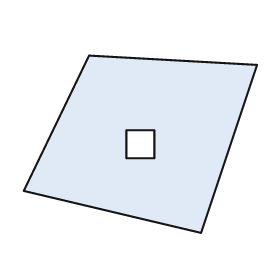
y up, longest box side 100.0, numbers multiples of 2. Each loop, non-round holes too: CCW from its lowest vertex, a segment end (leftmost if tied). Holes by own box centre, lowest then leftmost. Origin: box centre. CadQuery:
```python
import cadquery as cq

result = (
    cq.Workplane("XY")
    .moveTo(26.0, -38.0)
    .lineTo(50.0, 34.0)
    .lineTo(-22.0, 38.0)
    .lineTo(-50.0, -20.0)
    .close()
    .moveTo(-6.0, -6.0)
    .lineTo(6.0, -6.0)
    .lineTo(6.0, 6.0)
    .lineTo(-6.0, 6.0)
    .close()
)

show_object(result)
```